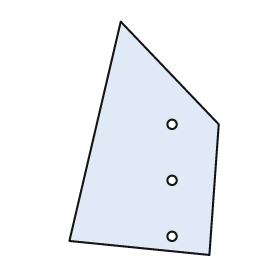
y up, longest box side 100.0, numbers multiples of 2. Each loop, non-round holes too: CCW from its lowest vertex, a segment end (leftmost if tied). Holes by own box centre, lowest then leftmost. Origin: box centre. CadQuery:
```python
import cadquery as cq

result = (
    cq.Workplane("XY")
    .moveTo(28.0, -50.0)
    .lineTo(32.0, 6.0)
    .lineTo(-10.0, 50.0)
    .lineTo(-32.0, -44.0)
    .close()
    .moveTo(12.0, -42.0)
    .circle(2.0)
    .moveTo(12.0, -18.0)
    .circle(2.0)
    .moveTo(12.0, 6.0)
    .circle(2.0)
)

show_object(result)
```